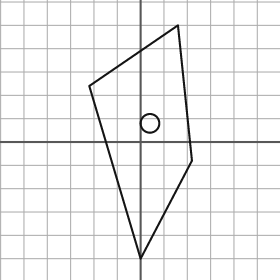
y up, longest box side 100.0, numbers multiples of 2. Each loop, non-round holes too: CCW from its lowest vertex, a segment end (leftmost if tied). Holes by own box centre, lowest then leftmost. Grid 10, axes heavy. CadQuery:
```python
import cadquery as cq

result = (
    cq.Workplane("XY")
    .moveTo(0.0, -50.0)
    .lineTo(22.0, -8.0)
    .lineTo(16.0, 50.0)
    .lineTo(-22.0, 24.0)
    .close()
    .moveTo(4.0, 8.0)
    .circle(4.0)
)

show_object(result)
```